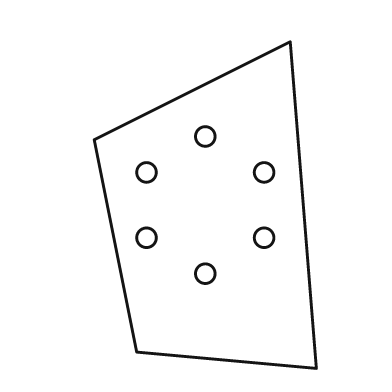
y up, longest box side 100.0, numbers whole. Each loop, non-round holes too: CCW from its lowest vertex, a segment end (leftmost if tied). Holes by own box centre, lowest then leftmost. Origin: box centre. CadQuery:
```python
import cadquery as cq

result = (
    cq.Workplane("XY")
    .moveTo(34.0, -50.0)
    .lineTo(26.0, 50.0)
    .lineTo(-34.0, 20.0)
    .lineTo(-21.0, -45.0)
    .close()
    .moveTo(0.0, -21.0)
    .circle(3.0)
    .moveTo(-18.0, -10.0)
    .circle(3.0)
    .moveTo(18.0, -10.0)
    .circle(3.0)
    .moveTo(-18.0, 10.0)
    .circle(3.0)
    .moveTo(18.0, 10.0)
    .circle(3.0)
    .moveTo(0.0, 21.0)
    .circle(3.0)
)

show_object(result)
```